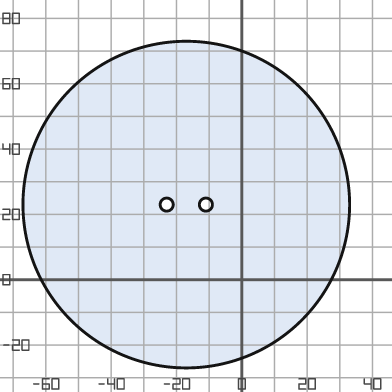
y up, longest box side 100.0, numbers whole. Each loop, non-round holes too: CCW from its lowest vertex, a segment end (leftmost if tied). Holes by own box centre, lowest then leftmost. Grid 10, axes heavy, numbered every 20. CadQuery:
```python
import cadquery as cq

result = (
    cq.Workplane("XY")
    .moveTo(-17.0, 23.0)
    .circle(50.0)
    .moveTo(-23.0, 23.0)
    .circle(2.0)
    .moveTo(-11.0, 23.0)
    .circle(2.0)
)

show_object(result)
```